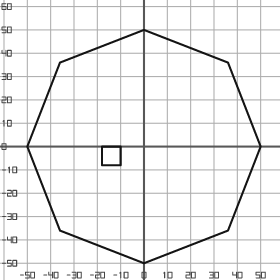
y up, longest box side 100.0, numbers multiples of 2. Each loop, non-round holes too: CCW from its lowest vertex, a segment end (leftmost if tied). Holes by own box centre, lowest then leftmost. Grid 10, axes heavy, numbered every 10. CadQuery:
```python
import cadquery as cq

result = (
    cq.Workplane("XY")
    .moveTo(0.0, -50.0)
    .lineTo(36.0, -36.0)
    .lineTo(50.0, 0.0)
    .lineTo(36.0, 36.0)
    .lineTo(0.0, 50.0)
    .lineTo(-36.0, 36.0)
    .lineTo(-50.0, 0.0)
    .lineTo(-36.0, -36.0)
    .close()
    .moveTo(-18.0, -8.0)
    .lineTo(-10.0, -8.0)
    .lineTo(-10.0, 0.0)
    .lineTo(-18.0, 0.0)
    .close()
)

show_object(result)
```